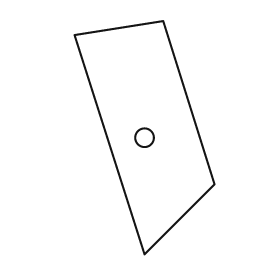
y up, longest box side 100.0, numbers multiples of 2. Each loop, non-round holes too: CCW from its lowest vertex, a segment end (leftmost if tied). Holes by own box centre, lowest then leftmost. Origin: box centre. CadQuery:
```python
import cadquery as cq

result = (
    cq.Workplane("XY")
    .moveTo(0.0, -50.0)
    .lineTo(30.0, -20.0)
    .lineTo(8.0, 50.0)
    .lineTo(-30.0, 44.0)
    .close()
    .moveTo(0.0, 0.0)
    .circle(4.0)
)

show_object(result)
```